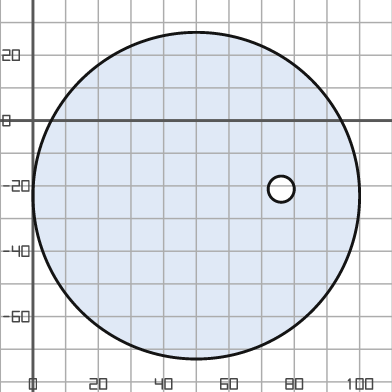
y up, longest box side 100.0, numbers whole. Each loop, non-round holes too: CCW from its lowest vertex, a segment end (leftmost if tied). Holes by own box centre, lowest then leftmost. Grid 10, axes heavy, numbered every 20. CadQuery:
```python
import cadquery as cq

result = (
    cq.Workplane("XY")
    .moveTo(50.0, -23.0)
    .circle(50.0)
    .moveTo(76.0, -21.0)
    .circle(4.0)
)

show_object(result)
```